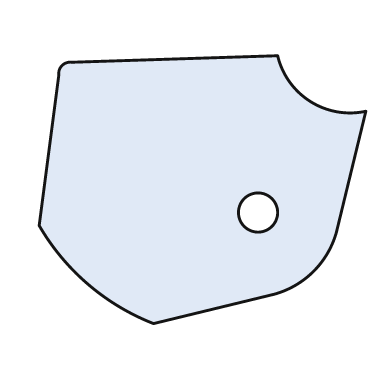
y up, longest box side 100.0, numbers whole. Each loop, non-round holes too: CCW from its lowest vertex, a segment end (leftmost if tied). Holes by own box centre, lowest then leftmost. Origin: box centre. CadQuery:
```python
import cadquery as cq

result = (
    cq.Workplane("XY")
    .moveTo(-15.0, -41.0)
    .lineTo(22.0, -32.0)
    .threePointArc((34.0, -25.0), (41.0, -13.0))
    .lineTo(50.0, 24.0)
    .threePointArc((33.0, 27.0), (23.0, 41.0))
    .lineTo(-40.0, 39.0)
    .threePointArc((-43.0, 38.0), (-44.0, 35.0))
    .lineTo(-50.0, -11.0)
    .threePointArc((-35.0, -29.0), (-15.0, -41.0))
    .close()
    .moveTo(17.0, -7.0)
    .circle(6.0)
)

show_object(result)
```